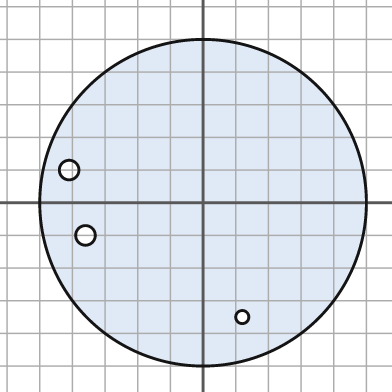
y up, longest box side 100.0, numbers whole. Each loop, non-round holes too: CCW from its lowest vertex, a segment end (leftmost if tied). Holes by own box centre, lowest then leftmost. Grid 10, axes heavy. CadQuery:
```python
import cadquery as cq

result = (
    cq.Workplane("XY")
    .moveTo(0.0, 0.0)
    .circle(50.0)
    .moveTo(12.0, -35.0)
    .circle(2.0)
    .moveTo(-36.0, -10.0)
    .circle(3.0)
    .moveTo(-41.0, 10.0)
    .circle(3.0)
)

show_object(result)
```